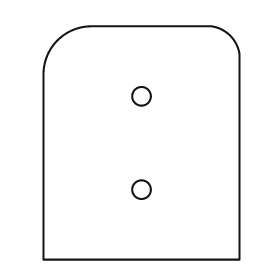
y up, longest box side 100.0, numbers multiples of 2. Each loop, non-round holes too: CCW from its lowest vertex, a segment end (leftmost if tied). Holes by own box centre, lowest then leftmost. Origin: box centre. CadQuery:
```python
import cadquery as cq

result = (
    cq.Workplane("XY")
    .moveTo(-42.0, -50.0)
    .lineTo(42.0, -50.0)
    .lineTo(42.0, 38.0)
    .threePointArc((38.0, 46.0), (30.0, 50.0))
    .lineTo(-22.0, 50.0)
    .threePointArc((-36.0, 44.0), (-42.0, 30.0))
    .close()
    .moveTo(0.0, -20.0)
    .circle(4.0)
    .moveTo(0.0, 20.0)
    .circle(4.0)
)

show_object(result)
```